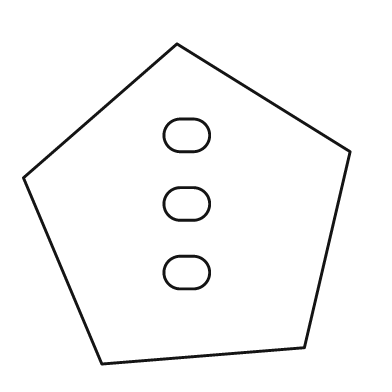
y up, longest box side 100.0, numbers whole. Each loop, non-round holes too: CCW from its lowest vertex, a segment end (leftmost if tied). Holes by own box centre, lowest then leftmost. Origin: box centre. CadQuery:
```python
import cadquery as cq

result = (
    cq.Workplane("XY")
    .moveTo(-26.0, -49.0)
    .lineTo(36.0, -44.0)
    .lineTo(50.0, 16.0)
    .lineTo(-3.0, 49.0)
    .lineTo(-50.0, 8.0)
    .close()
    .moveTo(-2.0, -26.0)
    .lineTo(2.0, -26.0)
    .threePointArc((7.0, -21.0), (2.0, -16.0))
    .lineTo(-2.0, -16.0)
    .threePointArc((-7.0, -21.0), (-2.0, -26.0))
    .close()
    .moveTo(-2.0, -5.0)
    .lineTo(2.0, -5.0)
    .threePointArc((7.0, 0.0), (2.0, 5.0))
    .lineTo(-2.0, 5.0)
    .threePointArc((-7.0, 0.0), (-2.0, -5.0))
    .close()
    .moveTo(-2.0, 16.0)
    .lineTo(2.0, 16.0)
    .threePointArc((7.0, 21.0), (2.0, 26.0))
    .lineTo(-2.0, 26.0)
    .threePointArc((-7.0, 21.0), (-2.0, 16.0))
    .close()
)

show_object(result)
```